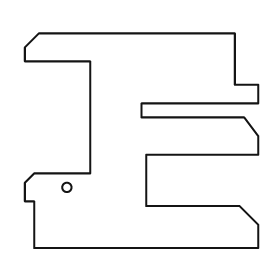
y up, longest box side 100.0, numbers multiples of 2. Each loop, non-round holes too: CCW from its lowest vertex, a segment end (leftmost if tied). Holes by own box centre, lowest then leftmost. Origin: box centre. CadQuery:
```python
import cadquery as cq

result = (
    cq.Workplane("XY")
    .moveTo(-46.0, -46.0)
    .lineTo(50.0, -46.0)
    .lineTo(50.0, -36.0)
    .lineTo(42.0, -28.0)
    .lineTo(2.0, -28.0)
    .lineTo(2.0, -6.0)
    .lineTo(50.0, -6.0)
    .lineTo(50.0, 2.0)
    .lineTo(44.0, 10.0)
    .lineTo(0.0, 10.0)
    .lineTo(0.0, 16.0)
    .lineTo(50.0, 16.0)
    .lineTo(50.0, 24.0)
    .lineTo(40.0, 24.0)
    .lineTo(40.0, 46.0)
    .lineTo(-44.0, 46.0)
    .lineTo(-50.0, 40.0)
    .lineTo(-50.0, 34.0)
    .lineTo(-22.0, 34.0)
    .lineTo(-22.0, -14.0)
    .lineTo(-46.0, -14.0)
    .lineTo(-50.0, -18.0)
    .lineTo(-50.0, -26.0)
    .lineTo(-46.0, -26.0)
    .close()
    .moveTo(-32.0, -20.0)
    .circle(2.0)
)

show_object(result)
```